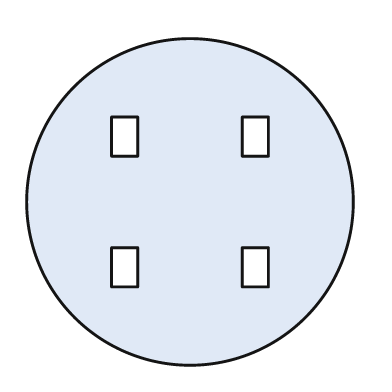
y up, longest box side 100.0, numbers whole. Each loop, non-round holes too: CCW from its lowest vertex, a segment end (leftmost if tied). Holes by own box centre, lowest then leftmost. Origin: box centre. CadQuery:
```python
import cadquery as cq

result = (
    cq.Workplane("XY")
    .moveTo(0.0, 0.0)
    .circle(50.0)
    .moveTo(-24.0, -26.0)
    .lineTo(-16.0, -26.0)
    .lineTo(-16.0, -14.0)
    .lineTo(-24.0, -14.0)
    .close()
    .moveTo(16.0, -26.0)
    .lineTo(24.0, -26.0)
    .lineTo(24.0, -14.0)
    .lineTo(16.0, -14.0)
    .close()
    .moveTo(-24.0, 14.0)
    .lineTo(-16.0, 14.0)
    .lineTo(-16.0, 26.0)
    .lineTo(-24.0, 26.0)
    .close()
    .moveTo(16.0, 14.0)
    .lineTo(24.0, 14.0)
    .lineTo(24.0, 26.0)
    .lineTo(16.0, 26.0)
    .close()
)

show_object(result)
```